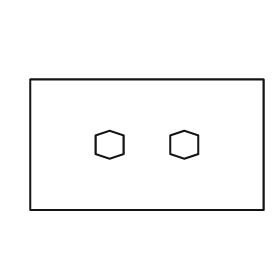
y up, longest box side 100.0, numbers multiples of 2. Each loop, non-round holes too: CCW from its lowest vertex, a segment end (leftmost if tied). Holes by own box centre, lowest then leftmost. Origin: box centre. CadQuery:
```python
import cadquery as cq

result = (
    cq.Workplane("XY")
    .moveTo(-50.0, -28.0)
    .lineTo(50.0, -28.0)
    .lineTo(50.0, 28.0)
    .lineTo(-50.0, 28.0)
    .close()
    .moveTo(-16.0, -6.0)
    .lineTo(-10.0, -4.0)
    .lineTo(-10.0, 4.0)
    .lineTo(-16.0, 6.0)
    .lineTo(-22.0, 4.0)
    .lineTo(-22.0, -4.0)
    .close()
    .moveTo(16.0, -6.0)
    .lineTo(22.0, -4.0)
    .lineTo(22.0, 4.0)
    .lineTo(16.0, 6.0)
    .lineTo(10.0, 4.0)
    .lineTo(10.0, -4.0)
    .close()
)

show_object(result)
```